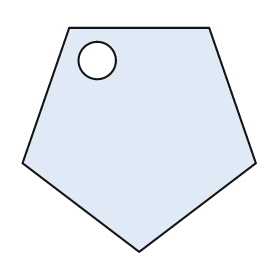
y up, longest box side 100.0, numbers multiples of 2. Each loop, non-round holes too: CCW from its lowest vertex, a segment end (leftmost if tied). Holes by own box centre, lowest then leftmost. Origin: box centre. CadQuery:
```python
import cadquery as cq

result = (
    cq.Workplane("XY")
    .moveTo(0.0, -48.0)
    .lineTo(50.0, -10.0)
    .lineTo(30.0, 48.0)
    .lineTo(-30.0, 48.0)
    .lineTo(-50.0, -10.0)
    .close()
    .moveTo(-18.0, 34.0)
    .circle(8.0)
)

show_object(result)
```